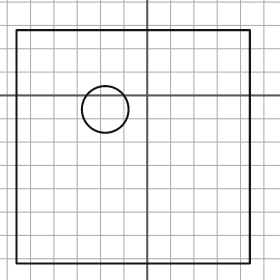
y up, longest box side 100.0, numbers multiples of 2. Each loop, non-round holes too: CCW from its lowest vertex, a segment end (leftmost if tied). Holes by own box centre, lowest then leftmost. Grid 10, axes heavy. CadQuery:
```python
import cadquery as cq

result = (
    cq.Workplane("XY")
    .moveTo(-56.0, -72.0)
    .lineTo(44.0, -72.0)
    .lineTo(44.0, 28.0)
    .lineTo(-56.0, 28.0)
    .close()
    .moveTo(-18.0, -6.0)
    .circle(10.0)
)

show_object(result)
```